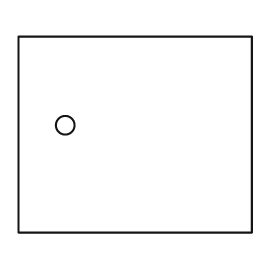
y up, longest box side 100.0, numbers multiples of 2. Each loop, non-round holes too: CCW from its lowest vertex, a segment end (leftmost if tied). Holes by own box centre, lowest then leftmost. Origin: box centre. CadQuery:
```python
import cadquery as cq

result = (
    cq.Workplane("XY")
    .moveTo(-50.0, -42.0)
    .lineTo(50.0, -42.0)
    .lineTo(50.0, 42.0)
    .lineTo(-50.0, 42.0)
    .close()
    .moveTo(-30.0, 4.0)
    .circle(4.0)
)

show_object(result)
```